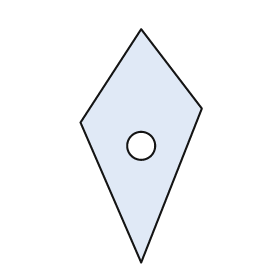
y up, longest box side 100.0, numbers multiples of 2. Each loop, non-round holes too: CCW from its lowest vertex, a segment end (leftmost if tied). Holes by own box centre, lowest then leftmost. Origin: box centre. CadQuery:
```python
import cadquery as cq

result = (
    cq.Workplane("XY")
    .moveTo(0.0, -50.0)
    .lineTo(26.0, 16.0)
    .lineTo(0.0, 50.0)
    .lineTo(-26.0, 10.0)
    .close()
    .moveTo(0.0, 0.0)
    .circle(6.0)
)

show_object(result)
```